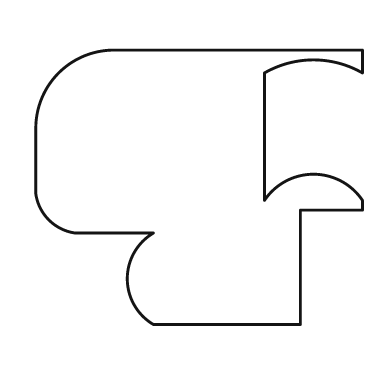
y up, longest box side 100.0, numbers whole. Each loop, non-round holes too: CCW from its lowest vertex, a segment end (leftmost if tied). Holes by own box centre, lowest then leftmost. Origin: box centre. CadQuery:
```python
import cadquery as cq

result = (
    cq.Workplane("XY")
    .moveTo(-14.0, -42.0)
    .lineTo(31.0, -42.0)
    .lineTo(31.0, -7.0)
    .lineTo(50.0, -7.0)
    .lineTo(50.0, -4.0)
    .threePointArc((35.0, 4.0), (20.0, -4.0))
    .lineTo(20.0, 35.0)
    .threePointArc((35.0, 39.0), (50.0, 35.0))
    .lineTo(50.0, 42.0)
    .lineTo(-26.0, 42.0)
    .threePointArc((-43.0, 35.0), (-50.0, 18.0))
    .lineTo(-50.0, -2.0)
    .threePointArc((-46.0, -10.0), (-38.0, -14.0))
    .lineTo(-14.0, -14.0)
    .threePointArc((-22.0, -28.0), (-14.0, -42.0))
    .close()
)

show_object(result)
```